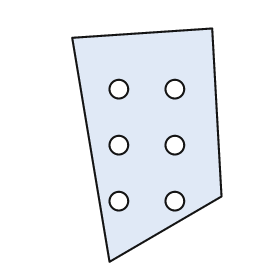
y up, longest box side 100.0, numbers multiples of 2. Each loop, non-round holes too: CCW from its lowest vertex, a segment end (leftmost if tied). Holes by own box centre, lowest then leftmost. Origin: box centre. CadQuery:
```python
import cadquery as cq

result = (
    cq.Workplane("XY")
    .moveTo(-16.0, -50.0)
    .lineTo(32.0, -22.0)
    .lineTo(28.0, 50.0)
    .lineTo(-32.0, 46.0)
    .close()
    .moveTo(-12.0, -24.0)
    .circle(4.0)
    .moveTo(12.0, -24.0)
    .circle(4.0)
    .moveTo(-12.0, 0.0)
    .circle(4.0)
    .moveTo(12.0, 0.0)
    .circle(4.0)
    .moveTo(-12.0, 24.0)
    .circle(4.0)
    .moveTo(12.0, 24.0)
    .circle(4.0)
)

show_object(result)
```